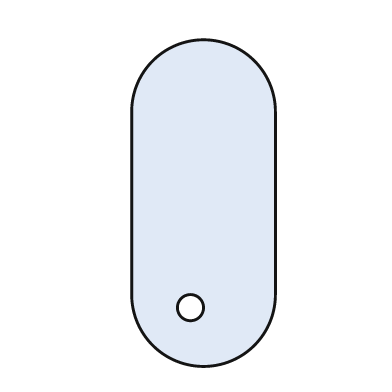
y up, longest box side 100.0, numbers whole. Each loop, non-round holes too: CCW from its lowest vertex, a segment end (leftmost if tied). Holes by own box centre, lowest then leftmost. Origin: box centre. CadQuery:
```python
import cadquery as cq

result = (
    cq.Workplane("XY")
    .moveTo(-22.0, -28.0)
    .threePointArc((0.0, -50.0), (22.0, -28.0))
    .lineTo(22.0, 28.0)
    .threePointArc((0.0, 50.0), (-22.0, 28.0))
    .close()
    .moveTo(-4.0, -32.0)
    .circle(4.0)
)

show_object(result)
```